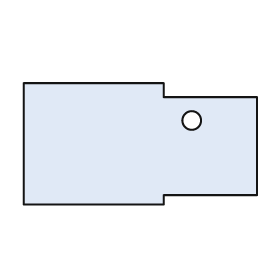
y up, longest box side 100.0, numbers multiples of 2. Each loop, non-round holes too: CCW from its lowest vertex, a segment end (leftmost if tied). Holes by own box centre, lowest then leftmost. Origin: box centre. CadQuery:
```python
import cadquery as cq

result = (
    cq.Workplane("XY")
    .moveTo(-50.0, -26.0)
    .lineTo(10.0, -26.0)
    .lineTo(10.0, -22.0)
    .lineTo(50.0, -22.0)
    .lineTo(50.0, 20.0)
    .lineTo(10.0, 20.0)
    .lineTo(10.0, 26.0)
    .lineTo(-50.0, 26.0)
    .close()
    .moveTo(22.0, 10.0)
    .circle(4.0)
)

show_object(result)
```